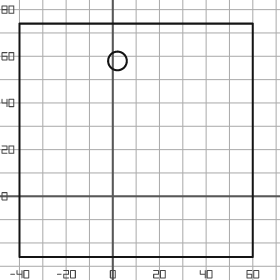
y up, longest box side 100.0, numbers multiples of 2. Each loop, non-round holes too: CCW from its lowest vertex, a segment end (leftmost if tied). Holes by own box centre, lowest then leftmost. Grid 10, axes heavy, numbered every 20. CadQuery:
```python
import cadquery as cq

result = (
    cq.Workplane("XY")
    .moveTo(-40.0, -26.0)
    .lineTo(60.0, -26.0)
    .lineTo(60.0, 74.0)
    .lineTo(-40.0, 74.0)
    .close()
    .moveTo(2.0, 58.0)
    .circle(4.0)
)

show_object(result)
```